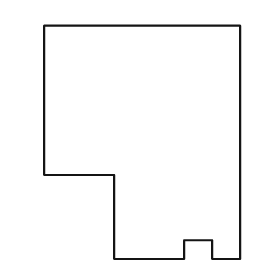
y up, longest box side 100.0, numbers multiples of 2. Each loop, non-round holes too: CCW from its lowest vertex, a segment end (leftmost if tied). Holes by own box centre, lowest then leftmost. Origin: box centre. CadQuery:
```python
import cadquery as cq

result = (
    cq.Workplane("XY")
    .moveTo(-12.0, -50.0)
    .lineTo(18.0, -50.0)
    .lineTo(18.0, -42.0)
    .lineTo(30.0, -42.0)
    .lineTo(30.0, -50.0)
    .lineTo(42.0, -50.0)
    .lineTo(42.0, 50.0)
    .lineTo(-42.0, 50.0)
    .lineTo(-42.0, -14.0)
    .lineTo(-12.0, -14.0)
    .close()
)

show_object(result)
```